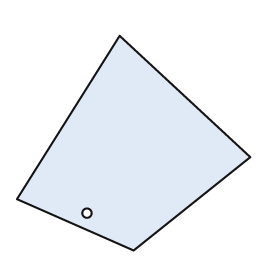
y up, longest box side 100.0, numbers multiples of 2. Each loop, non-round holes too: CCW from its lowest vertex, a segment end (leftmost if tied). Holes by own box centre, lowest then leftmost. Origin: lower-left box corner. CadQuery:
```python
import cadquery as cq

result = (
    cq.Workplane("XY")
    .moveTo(50.0, 0.0)
    .lineTo(100.0, 40.0)
    .lineTo(44.0, 92.0)
    .lineTo(0.0, 22.0)
    .close()
    .moveTo(30.0, 16.0)
    .circle(2.0)
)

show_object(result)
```